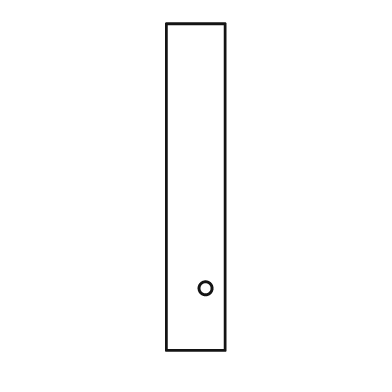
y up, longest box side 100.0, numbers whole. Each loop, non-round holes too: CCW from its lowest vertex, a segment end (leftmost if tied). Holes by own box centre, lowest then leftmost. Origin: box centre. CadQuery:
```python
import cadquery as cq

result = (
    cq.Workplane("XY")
    .moveTo(-9.0, -50.0)
    .lineTo(9.0, -50.0)
    .lineTo(9.0, 50.0)
    .lineTo(-9.0, 50.0)
    .close()
    .moveTo(3.0, -31.0)
    .circle(2.0)
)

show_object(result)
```